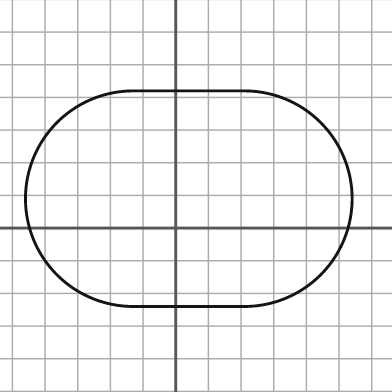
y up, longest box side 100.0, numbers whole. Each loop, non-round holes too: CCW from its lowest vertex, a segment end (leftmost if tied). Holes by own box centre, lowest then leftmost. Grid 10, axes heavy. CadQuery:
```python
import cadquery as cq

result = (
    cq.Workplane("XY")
    .moveTo(-13.0, -24.0)
    .lineTo(21.0, -24.0)
    .threePointArc((54.0, 9.0), (21.0, 42.0))
    .lineTo(-13.0, 42.0)
    .threePointArc((-46.0, 9.0), (-13.0, -24.0))
    .close()
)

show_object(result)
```